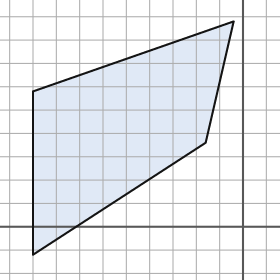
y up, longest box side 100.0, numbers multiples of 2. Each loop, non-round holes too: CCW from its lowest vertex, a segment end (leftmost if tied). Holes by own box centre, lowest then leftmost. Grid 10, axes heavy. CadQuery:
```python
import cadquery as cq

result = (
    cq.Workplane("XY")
    .moveTo(-90.0, -12.0)
    .lineTo(-16.0, 36.0)
    .lineTo(-4.0, 88.0)
    .lineTo(-90.0, 58.0)
    .close()
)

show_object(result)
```